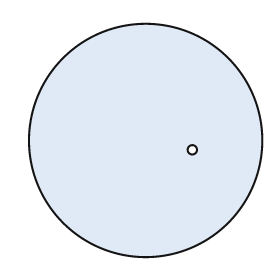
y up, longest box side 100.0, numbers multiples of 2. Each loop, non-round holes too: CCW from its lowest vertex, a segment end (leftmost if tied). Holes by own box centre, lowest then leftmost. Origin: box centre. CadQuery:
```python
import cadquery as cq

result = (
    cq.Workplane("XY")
    .moveTo(0.0, 0.0)
    .circle(50.0)
    .moveTo(20.0, -4.0)
    .circle(2.0)
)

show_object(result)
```